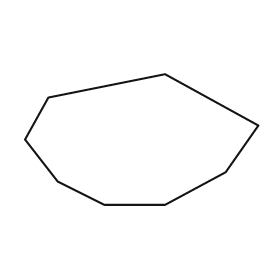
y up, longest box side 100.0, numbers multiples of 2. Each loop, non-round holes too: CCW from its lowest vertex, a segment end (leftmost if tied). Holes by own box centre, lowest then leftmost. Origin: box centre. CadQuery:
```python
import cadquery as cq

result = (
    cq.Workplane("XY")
    .moveTo(-16.0, -28.0)
    .lineTo(10.0, -28.0)
    .lineTo(36.0, -14.0)
    .lineTo(50.0, 6.0)
    .lineTo(10.0, 28.0)
    .lineTo(-40.0, 18.0)
    .lineTo(-50.0, 0.0)
    .lineTo(-36.0, -18.0)
    .close()
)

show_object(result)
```